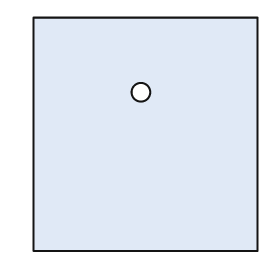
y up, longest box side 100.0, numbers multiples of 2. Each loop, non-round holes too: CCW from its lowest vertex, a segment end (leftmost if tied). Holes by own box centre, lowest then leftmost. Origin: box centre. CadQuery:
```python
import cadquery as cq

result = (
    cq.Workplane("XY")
    .moveTo(-48.0, -50.0)
    .lineTo(48.0, -50.0)
    .lineTo(48.0, 50.0)
    .lineTo(-48.0, 50.0)
    .close()
    .moveTo(-2.0, 18.0)
    .circle(4.0)
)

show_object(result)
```